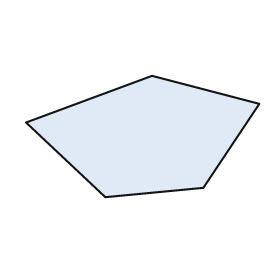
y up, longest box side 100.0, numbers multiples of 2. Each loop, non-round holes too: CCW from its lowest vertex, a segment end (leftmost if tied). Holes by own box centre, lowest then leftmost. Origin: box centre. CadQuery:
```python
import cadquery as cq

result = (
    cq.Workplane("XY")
    .moveTo(-16.0, -26.0)
    .lineTo(26.0, -22.0)
    .lineTo(50.0, 14.0)
    .lineTo(4.0, 26.0)
    .lineTo(-50.0, 6.0)
    .close()
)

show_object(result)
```